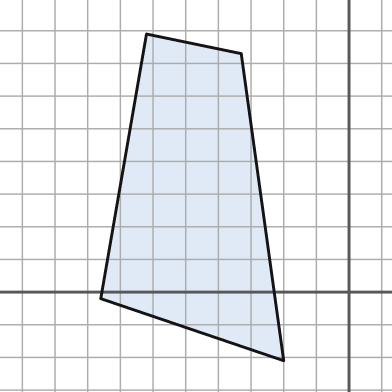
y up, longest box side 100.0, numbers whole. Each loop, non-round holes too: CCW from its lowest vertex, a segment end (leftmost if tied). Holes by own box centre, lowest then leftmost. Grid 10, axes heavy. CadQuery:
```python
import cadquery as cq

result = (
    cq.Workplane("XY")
    .moveTo(-20.0, -21.0)
    .lineTo(-33.0, 73.0)
    .lineTo(-62.0, 79.0)
    .lineTo(-76.0, -2.0)
    .close()
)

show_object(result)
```